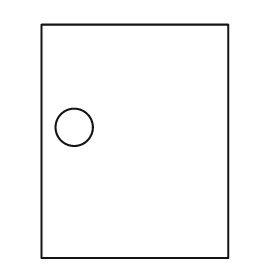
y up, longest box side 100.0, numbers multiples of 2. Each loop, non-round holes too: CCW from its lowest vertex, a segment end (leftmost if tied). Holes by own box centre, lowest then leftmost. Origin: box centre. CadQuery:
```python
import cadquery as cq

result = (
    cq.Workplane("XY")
    .moveTo(-40.0, -50.0)
    .lineTo(40.0, -50.0)
    .lineTo(40.0, 50.0)
    .lineTo(-40.0, 50.0)
    .close()
    .moveTo(-26.0, 6.0)
    .circle(8.0)
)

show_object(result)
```